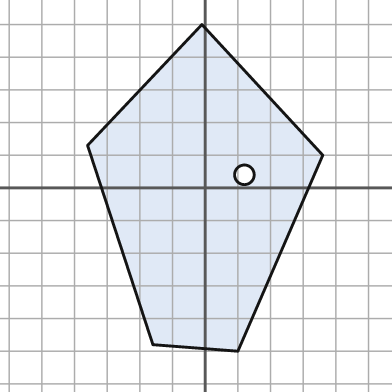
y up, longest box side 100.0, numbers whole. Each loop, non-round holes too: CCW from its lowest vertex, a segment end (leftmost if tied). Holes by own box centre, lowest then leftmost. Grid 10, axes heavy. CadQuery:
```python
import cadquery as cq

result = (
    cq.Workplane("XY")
    .moveTo(10.0, -50.0)
    .lineTo(36.0, 10.0)
    .lineTo(-1.0, 50.0)
    .lineTo(-36.0, 13.0)
    .lineTo(-16.0, -48.0)
    .close()
    .moveTo(12.0, 4.0)
    .circle(3.0)
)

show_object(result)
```